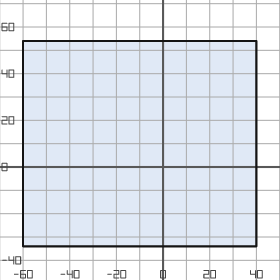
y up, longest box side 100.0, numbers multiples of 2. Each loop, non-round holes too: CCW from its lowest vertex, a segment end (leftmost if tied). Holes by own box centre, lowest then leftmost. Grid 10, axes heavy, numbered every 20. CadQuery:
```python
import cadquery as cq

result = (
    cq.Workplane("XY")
    .moveTo(-60.0, -34.0)
    .lineTo(40.0, -34.0)
    .lineTo(40.0, 54.0)
    .lineTo(-60.0, 54.0)
    .close()
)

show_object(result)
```